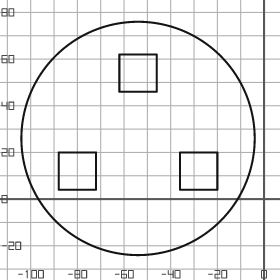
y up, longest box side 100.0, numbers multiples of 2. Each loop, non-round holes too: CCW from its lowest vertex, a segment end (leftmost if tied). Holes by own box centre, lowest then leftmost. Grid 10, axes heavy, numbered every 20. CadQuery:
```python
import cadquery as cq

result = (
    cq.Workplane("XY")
    .moveTo(-54.0, 26.0)
    .circle(50.0)
    .moveTo(-88.0, 4.0)
    .lineTo(-72.0, 4.0)
    .lineTo(-72.0, 20.0)
    .lineTo(-88.0, 20.0)
    .close()
    .moveTo(-36.0, 4.0)
    .lineTo(-20.0, 4.0)
    .lineTo(-20.0, 20.0)
    .lineTo(-36.0, 20.0)
    .close()
    .moveTo(-62.0, 46.0)
    .lineTo(-46.0, 46.0)
    .lineTo(-46.0, 62.0)
    .lineTo(-62.0, 62.0)
    .close()
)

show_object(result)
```